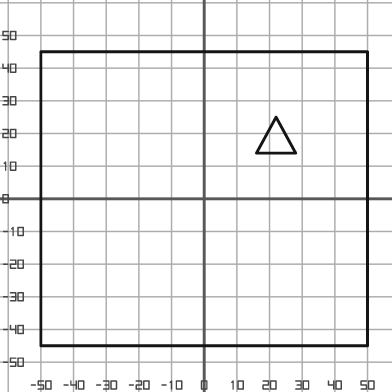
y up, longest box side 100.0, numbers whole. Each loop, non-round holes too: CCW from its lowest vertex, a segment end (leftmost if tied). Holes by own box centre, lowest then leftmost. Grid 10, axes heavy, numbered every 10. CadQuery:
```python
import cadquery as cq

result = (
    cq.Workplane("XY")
    .moveTo(-50.0, -45.0)
    .lineTo(50.0, -45.0)
    .lineTo(50.0, 45.0)
    .lineTo(-50.0, 45.0)
    .close()
    .moveTo(16.0, 14.0)
    .lineTo(28.0, 14.0)
    .lineTo(22.0, 25.0)
    .close()
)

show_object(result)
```